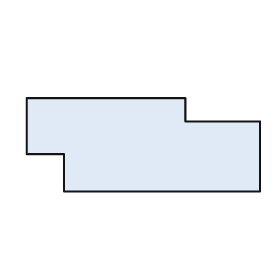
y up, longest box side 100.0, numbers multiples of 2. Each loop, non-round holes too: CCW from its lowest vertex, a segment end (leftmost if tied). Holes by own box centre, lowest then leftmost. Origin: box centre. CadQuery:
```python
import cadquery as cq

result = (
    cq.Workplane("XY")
    .moveTo(-34.0, -20.0)
    .lineTo(50.0, -20.0)
    .lineTo(50.0, 10.0)
    .lineTo(18.0, 10.0)
    .lineTo(18.0, 20.0)
    .lineTo(-50.0, 20.0)
    .lineTo(-50.0, -4.0)
    .lineTo(-34.0, -4.0)
    .close()
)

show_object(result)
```